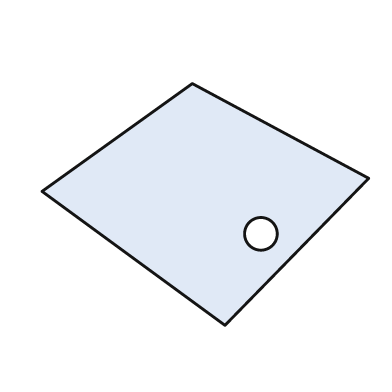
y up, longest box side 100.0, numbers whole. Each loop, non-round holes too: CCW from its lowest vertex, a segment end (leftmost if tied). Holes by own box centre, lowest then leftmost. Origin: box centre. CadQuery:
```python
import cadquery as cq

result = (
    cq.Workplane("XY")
    .moveTo(6.0, -37.0)
    .lineTo(50.0, 8.0)
    .lineTo(-4.0, 37.0)
    .lineTo(-50.0, 4.0)
    .close()
    .moveTo(17.0, -9.0)
    .circle(5.0)
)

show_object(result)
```